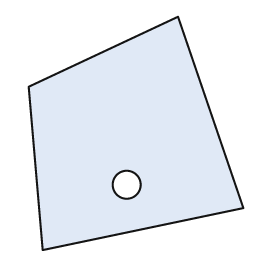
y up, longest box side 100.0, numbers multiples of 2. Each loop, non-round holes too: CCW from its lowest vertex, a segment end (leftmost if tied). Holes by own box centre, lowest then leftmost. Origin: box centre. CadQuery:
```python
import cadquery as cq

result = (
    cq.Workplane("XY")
    .moveTo(-40.0, -50.0)
    .lineTo(46.0, -32.0)
    .lineTo(18.0, 50.0)
    .lineTo(-46.0, 20.0)
    .close()
    .moveTo(-4.0, -22.0)
    .circle(6.0)
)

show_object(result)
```